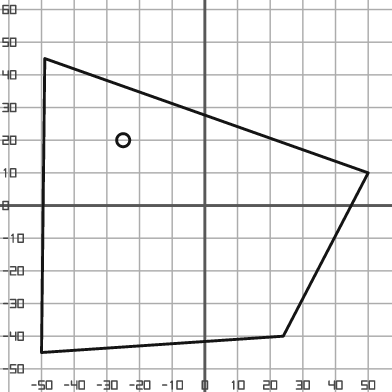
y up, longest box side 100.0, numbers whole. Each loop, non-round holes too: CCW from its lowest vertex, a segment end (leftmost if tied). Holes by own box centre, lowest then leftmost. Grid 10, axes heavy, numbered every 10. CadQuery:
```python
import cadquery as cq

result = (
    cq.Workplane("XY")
    .moveTo(-50.0, -45.0)
    .lineTo(24.0, -40.0)
    .lineTo(50.0, 10.0)
    .lineTo(-49.0, 45.0)
    .close()
    .moveTo(-25.0, 20.0)
    .circle(2.0)
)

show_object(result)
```